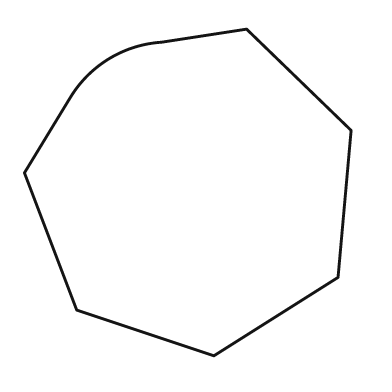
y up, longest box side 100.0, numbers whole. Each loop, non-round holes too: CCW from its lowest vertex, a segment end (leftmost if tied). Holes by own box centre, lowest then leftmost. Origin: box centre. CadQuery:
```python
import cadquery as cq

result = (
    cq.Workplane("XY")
    .moveTo(8.0, -50.0)
    .lineTo(46.0, -26.0)
    .lineTo(50.0, 19.0)
    .lineTo(18.0, 50.0)
    .lineTo(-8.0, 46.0)
    .threePointArc((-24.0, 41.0), (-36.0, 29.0))
    .lineTo(-50.0, 6.0)
    .lineTo(-34.0, -36.0)
    .close()
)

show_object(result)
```